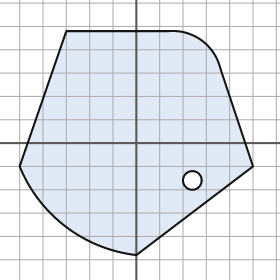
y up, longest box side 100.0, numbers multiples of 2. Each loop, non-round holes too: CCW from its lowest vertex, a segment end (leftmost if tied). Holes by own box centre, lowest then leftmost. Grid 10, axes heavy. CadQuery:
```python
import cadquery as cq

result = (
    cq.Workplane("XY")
    .moveTo(0.0, -48.0)
    .lineTo(50.0, -10.0)
    .lineTo(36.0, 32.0)
    .threePointArc((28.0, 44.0), (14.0, 48.0))
    .lineTo(-30.0, 48.0)
    .lineTo(-50.0, -10.0)
    .threePointArc((-30.0, -36.0), (0.0, -48.0))
    .close()
    .moveTo(24.0, -16.0)
    .circle(4.0)
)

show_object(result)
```